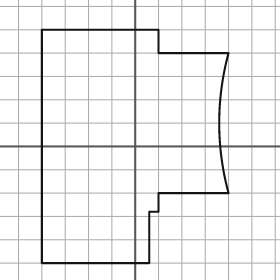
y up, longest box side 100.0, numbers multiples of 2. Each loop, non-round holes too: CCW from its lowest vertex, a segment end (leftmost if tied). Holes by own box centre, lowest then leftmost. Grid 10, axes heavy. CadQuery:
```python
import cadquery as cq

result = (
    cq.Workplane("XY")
    .moveTo(-40.0, -50.0)
    .lineTo(6.0, -50.0)
    .lineTo(6.0, -28.0)
    .lineTo(10.0, -28.0)
    .lineTo(10.0, -20.0)
    .lineTo(40.0, -20.0)
    .threePointArc((36.0, 10.0), (40.0, 40.0))
    .lineTo(10.0, 40.0)
    .lineTo(10.0, 50.0)
    .lineTo(-40.0, 50.0)
    .close()
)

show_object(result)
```